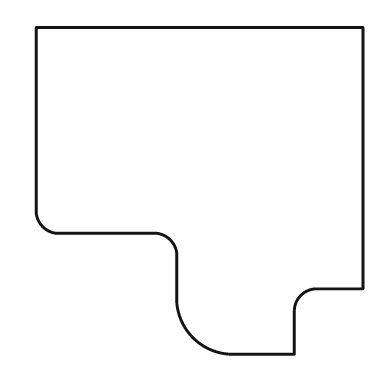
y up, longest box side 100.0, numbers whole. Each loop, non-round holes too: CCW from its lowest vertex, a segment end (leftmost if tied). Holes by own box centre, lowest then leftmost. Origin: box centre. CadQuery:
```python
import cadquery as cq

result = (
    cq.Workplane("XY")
    .moveTo(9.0, -50.0)
    .lineTo(29.0, -50.0)
    .lineTo(29.0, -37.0)
    .threePointArc((31.0, -32.0), (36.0, -30.0))
    .lineTo(50.0, -30.0)
    .lineTo(50.0, 50.0)
    .lineTo(-50.0, 50.0)
    .lineTo(-50.0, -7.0)
    .threePointArc((-48.0, -11.0), (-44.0, -13.0))
    .lineTo(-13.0, -13.0)
    .threePointArc((-9.0, -15.0), (-7.0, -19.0))
    .lineTo(-7.0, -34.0)
    .threePointArc((-2.0, -45.0), (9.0, -50.0))
    .close()
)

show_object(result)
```